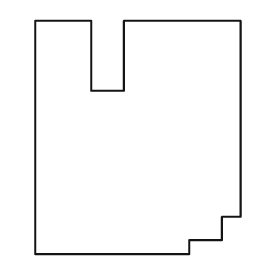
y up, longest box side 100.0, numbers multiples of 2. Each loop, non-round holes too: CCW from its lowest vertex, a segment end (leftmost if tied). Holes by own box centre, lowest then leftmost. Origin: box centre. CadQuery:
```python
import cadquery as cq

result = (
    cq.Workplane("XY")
    .moveTo(-44.0, -50.0)
    .lineTo(22.0, -50.0)
    .lineTo(22.0, -44.0)
    .lineTo(36.0, -44.0)
    .lineTo(36.0, -34.0)
    .lineTo(44.0, -34.0)
    .lineTo(44.0, 50.0)
    .lineTo(-6.0, 50.0)
    .lineTo(-6.0, 20.0)
    .lineTo(-20.0, 20.0)
    .lineTo(-20.0, 50.0)
    .lineTo(-44.0, 50.0)
    .close()
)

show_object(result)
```